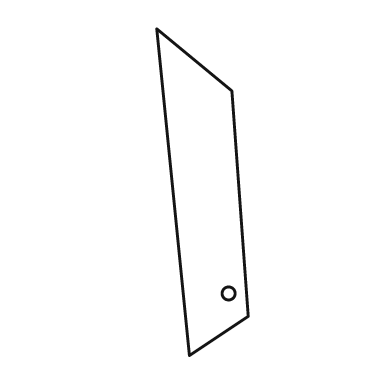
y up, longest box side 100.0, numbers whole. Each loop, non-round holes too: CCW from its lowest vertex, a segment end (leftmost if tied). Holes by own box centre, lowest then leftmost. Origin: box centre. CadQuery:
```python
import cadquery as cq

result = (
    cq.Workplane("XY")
    .moveTo(-4.0, -50.0)
    .lineTo(14.0, -38.0)
    .lineTo(9.0, 31.0)
    .lineTo(-14.0, 50.0)
    .close()
    .moveTo(8.0, -31.0)
    .circle(2.0)
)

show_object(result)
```